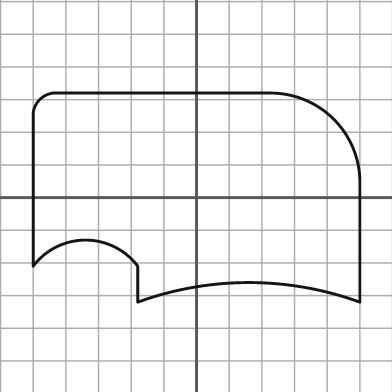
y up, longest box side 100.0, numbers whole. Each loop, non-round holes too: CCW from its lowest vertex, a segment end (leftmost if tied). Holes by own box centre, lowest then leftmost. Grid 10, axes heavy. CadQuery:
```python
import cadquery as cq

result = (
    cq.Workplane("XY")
    .moveTo(-18.0, -32.0)
    .threePointArc((16.0, -26.0), (50.0, -32.0))
    .lineTo(50.0, 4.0)
    .threePointArc((42.0, 24.0), (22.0, 32.0))
    .lineTo(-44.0, 32.0)
    .threePointArc((-48.0, 30.0), (-50.0, 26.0))
    .lineTo(-50.0, -21.0)
    .threePointArc((-34.0, -13.0), (-18.0, -21.0))
    .close()
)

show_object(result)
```